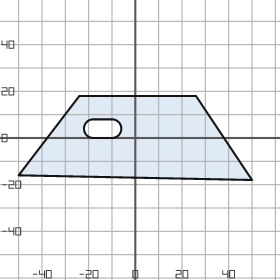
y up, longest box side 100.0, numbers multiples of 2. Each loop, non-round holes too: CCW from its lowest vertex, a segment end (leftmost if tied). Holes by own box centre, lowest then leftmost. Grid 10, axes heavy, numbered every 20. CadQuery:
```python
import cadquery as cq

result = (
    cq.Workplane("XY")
    .moveTo(50.0, -18.0)
    .lineTo(26.0, 18.0)
    .lineTo(-24.0, 18.0)
    .lineTo(-50.0, -16.0)
    .close()
    .moveTo(-18.0, 0.0)
    .lineTo(-10.0, 0.0)
    .threePointArc((-6.0, 4.0), (-10.0, 8.0))
    .lineTo(-18.0, 8.0)
    .threePointArc((-22.0, 4.0), (-18.0, 0.0))
    .close()
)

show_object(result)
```